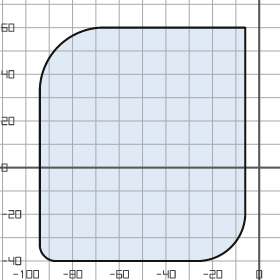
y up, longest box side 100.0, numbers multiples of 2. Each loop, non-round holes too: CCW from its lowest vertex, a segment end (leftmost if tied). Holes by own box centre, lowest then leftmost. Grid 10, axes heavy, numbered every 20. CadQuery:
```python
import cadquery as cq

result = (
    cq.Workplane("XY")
    .moveTo(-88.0, -40.0)
    .lineTo(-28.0, -40.0)
    .threePointArc((-12.0, -34.0), (-6.0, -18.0))
    .lineTo(-6.0, 60.0)
    .lineTo(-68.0, 60.0)
    .threePointArc((-86.0, 52.0), (-94.0, 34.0))
    .lineTo(-94.0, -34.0)
    .threePointArc((-92.0, -38.0), (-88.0, -40.0))
    .close()
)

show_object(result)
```